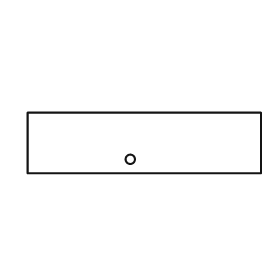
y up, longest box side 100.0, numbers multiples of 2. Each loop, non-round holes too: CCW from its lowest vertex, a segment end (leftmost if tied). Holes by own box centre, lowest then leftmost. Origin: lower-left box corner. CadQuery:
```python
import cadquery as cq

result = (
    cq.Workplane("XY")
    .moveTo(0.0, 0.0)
    .lineTo(100.0, 0.0)
    .lineTo(100.0, 26.0)
    .lineTo(0.0, 26.0)
    .close()
    .moveTo(44.0, 6.0)
    .circle(2.0)
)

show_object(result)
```